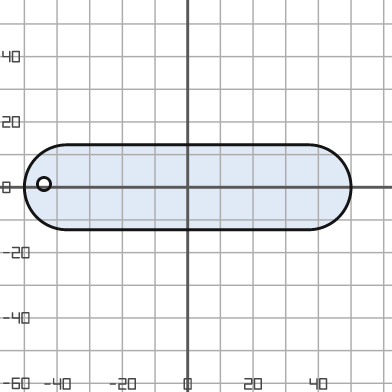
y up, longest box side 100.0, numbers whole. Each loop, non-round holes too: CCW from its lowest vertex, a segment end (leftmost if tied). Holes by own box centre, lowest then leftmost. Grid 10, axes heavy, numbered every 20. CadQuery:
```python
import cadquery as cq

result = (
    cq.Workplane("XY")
    .moveTo(-37.0, -13.0)
    .lineTo(37.0, -13.0)
    .threePointArc((50.0, 0.0), (37.0, 13.0))
    .lineTo(-37.0, 13.0)
    .threePointArc((-50.0, 0.0), (-37.0, -13.0))
    .close()
    .moveTo(-44.0, 1.0)
    .circle(2.0)
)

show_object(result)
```